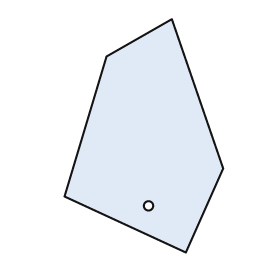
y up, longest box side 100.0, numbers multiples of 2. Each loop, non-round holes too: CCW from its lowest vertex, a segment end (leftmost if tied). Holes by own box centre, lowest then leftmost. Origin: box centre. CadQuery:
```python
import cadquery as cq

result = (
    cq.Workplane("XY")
    .moveTo(18.0, -50.0)
    .lineTo(34.0, -14.0)
    .lineTo(12.0, 50.0)
    .lineTo(-16.0, 34.0)
    .lineTo(-34.0, -26.0)
    .close()
    .moveTo(2.0, -30.0)
    .circle(2.0)
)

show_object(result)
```